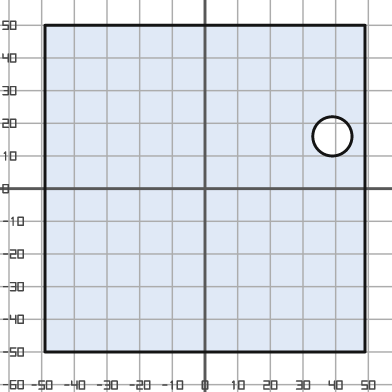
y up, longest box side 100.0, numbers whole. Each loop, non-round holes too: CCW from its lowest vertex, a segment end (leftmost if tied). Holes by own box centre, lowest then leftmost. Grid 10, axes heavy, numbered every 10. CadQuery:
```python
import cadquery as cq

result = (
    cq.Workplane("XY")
    .moveTo(-49.0, -50.0)
    .lineTo(49.0, -50.0)
    .lineTo(49.0, 50.0)
    .lineTo(-49.0, 50.0)
    .close()
    .moveTo(39.0, 16.0)
    .circle(6.0)
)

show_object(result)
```